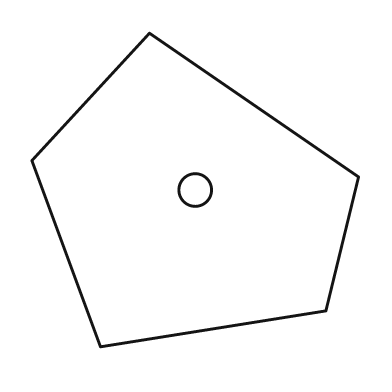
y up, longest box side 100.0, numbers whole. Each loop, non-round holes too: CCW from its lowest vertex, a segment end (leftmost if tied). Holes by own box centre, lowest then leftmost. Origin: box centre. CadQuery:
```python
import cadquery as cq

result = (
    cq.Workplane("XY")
    .moveTo(-29.0, -48.0)
    .lineTo(40.0, -37.0)
    .lineTo(50.0, 4.0)
    .lineTo(-14.0, 48.0)
    .lineTo(-50.0, 9.0)
    .close()
    .moveTo(0.0, 0.0)
    .circle(5.0)
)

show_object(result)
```